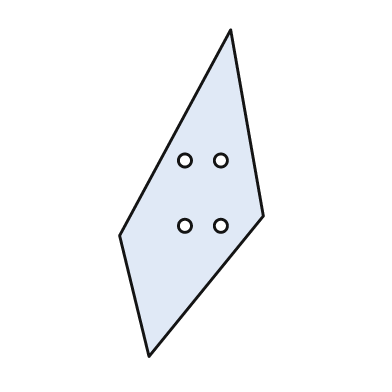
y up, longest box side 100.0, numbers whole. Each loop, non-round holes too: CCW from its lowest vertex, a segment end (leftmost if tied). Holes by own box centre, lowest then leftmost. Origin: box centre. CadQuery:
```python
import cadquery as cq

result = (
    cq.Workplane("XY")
    .moveTo(-13.0, -50.0)
    .lineTo(22.0, -7.0)
    .lineTo(12.0, 50.0)
    .lineTo(-22.0, -13.0)
    .close()
    .moveTo(-2.0, -10.0)
    .circle(2.0)
    .moveTo(9.0, -10.0)
    .circle(2.0)
    .moveTo(-2.0, 10.0)
    .circle(2.0)
    .moveTo(9.0, 10.0)
    .circle(2.0)
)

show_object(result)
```